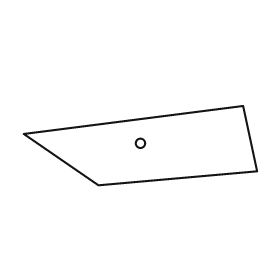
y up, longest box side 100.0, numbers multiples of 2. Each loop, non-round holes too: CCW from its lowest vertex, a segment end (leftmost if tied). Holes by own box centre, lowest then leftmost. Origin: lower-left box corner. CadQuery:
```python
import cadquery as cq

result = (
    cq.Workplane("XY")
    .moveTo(32.0, 0.0)
    .lineTo(100.0, 6.0)
    .lineTo(94.0, 34.0)
    .lineTo(0.0, 22.0)
    .close()
    .moveTo(50.0, 18.0)
    .circle(2.0)
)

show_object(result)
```